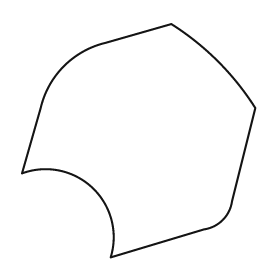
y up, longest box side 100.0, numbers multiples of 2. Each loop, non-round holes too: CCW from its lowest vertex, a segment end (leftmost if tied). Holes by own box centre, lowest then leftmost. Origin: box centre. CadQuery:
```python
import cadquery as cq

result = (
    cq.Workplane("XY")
    .moveTo(-12.0, -50.0)
    .lineTo(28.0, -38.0)
    .threePointArc((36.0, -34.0), (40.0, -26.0))
    .lineTo(50.0, 14.0)
    .threePointArc((34.0, 34.0), (14.0, 50.0))
    .lineTo(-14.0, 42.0)
    .threePointArc((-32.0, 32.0), (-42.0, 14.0))
    .lineTo(-50.0, -14.0)
    .threePointArc((-20.0, -20.0), (-12.0, -50.0))
    .close()
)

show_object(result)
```